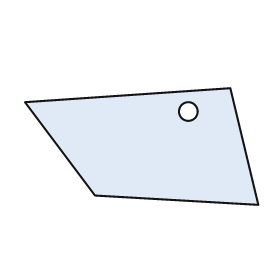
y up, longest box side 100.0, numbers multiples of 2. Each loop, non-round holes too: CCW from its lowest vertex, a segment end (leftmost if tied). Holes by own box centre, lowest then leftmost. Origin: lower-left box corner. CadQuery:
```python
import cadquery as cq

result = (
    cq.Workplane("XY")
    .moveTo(100.0, 0.0)
    .lineTo(88.0, 50.0)
    .lineTo(0.0, 44.0)
    .lineTo(30.0, 4.0)
    .close()
    .moveTo(70.0, 40.0)
    .circle(4.0)
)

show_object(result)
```